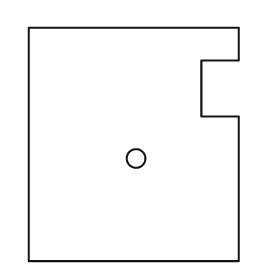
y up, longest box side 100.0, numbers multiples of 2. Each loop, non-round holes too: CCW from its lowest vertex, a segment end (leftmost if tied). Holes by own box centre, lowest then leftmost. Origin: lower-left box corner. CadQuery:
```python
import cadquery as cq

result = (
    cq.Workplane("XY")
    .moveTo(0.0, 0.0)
    .lineTo(90.0, 0.0)
    .lineTo(90.0, 62.0)
    .lineTo(74.0, 62.0)
    .lineTo(74.0, 86.0)
    .lineTo(90.0, 86.0)
    .lineTo(90.0, 100.0)
    .lineTo(0.0, 100.0)
    .close()
    .moveTo(46.0, 44.0)
    .circle(4.0)
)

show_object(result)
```